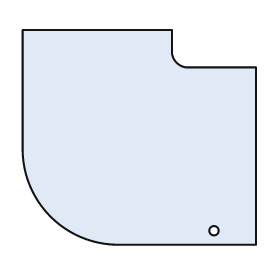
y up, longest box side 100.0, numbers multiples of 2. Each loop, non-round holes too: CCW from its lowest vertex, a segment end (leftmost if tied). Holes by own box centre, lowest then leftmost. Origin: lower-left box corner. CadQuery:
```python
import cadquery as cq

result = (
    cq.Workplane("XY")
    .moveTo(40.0, 0.0)
    .lineTo(100.0, 0.0)
    .lineTo(100.0, 76.0)
    .lineTo(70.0, 76.0)
    .threePointArc((66.0, 78.0), (64.0, 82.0))
    .lineTo(64.0, 92.0)
    .lineTo(0.0, 92.0)
    .lineTo(0.0, 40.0)
    .threePointArc((12.0, 12.0), (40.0, 0.0))
    .close()
    .moveTo(82.0, 6.0)
    .circle(2.0)
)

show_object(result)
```